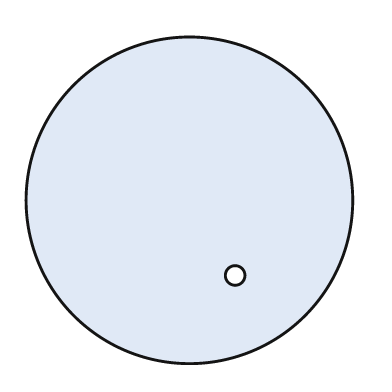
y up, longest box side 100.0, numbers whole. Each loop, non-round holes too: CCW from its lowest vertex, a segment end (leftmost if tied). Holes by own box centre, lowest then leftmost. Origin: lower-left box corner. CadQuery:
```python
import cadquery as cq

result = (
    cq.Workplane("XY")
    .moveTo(50.0, 50.0)
    .circle(50.0)
    .moveTo(64.0, 27.0)
    .circle(3.0)
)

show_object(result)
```